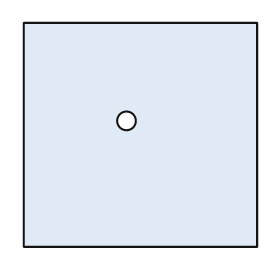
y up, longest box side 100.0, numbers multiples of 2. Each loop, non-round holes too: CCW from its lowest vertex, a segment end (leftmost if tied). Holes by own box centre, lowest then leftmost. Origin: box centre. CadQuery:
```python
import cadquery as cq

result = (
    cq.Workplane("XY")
    .moveTo(-50.0, -48.0)
    .lineTo(50.0, -48.0)
    .lineTo(50.0, 48.0)
    .lineTo(-50.0, 48.0)
    .close()
    .moveTo(-6.0, 6.0)
    .circle(4.0)
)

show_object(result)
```